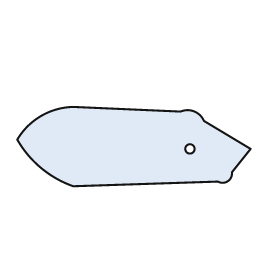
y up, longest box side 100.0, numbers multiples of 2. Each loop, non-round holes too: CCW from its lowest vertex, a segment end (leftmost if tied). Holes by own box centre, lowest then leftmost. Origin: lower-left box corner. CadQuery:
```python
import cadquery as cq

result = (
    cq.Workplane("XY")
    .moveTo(24.0, 0.0)
    .lineTo(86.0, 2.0)
    .threePointArc((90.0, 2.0), (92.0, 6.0))
    .lineTo(100.0, 16.0)
    .lineTo(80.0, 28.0)
    .threePointArc((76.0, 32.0), (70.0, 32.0))
    .lineTo(24.0, 34.0)
    .threePointArc((10.0, 30.0), (0.0, 20.0))
    .threePointArc((10.0, 8.0), (24.0, 0.0))
    .close()
    .moveTo(74.0, 16.0)
    .circle(2.0)
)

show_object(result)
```